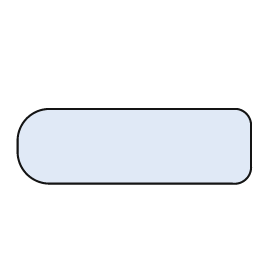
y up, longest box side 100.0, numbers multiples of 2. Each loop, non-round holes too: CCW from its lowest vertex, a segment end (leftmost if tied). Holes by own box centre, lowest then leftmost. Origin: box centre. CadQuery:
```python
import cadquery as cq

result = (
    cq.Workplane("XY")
    .moveTo(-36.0, -16.0)
    .lineTo(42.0, -16.0)
    .threePointArc((48.0, -14.0), (50.0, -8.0))
    .lineTo(50.0, 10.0)
    .threePointArc((48.0, 14.0), (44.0, 16.0))
    .lineTo(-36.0, 16.0)
    .threePointArc((-46.0, 12.0), (-50.0, 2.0))
    .lineTo(-50.0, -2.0)
    .threePointArc((-46.0, -12.0), (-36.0, -16.0))
    .close()
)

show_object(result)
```